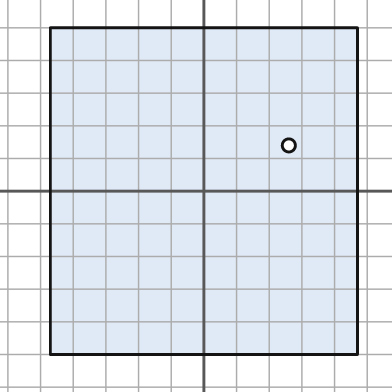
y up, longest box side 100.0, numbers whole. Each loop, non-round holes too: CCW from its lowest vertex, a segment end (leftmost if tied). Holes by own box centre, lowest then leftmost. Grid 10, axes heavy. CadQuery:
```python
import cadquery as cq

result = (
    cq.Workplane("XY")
    .moveTo(-47.0, -50.0)
    .lineTo(47.0, -50.0)
    .lineTo(47.0, 50.0)
    .lineTo(-47.0, 50.0)
    .close()
    .moveTo(26.0, 14.0)
    .circle(2.0)
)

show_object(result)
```